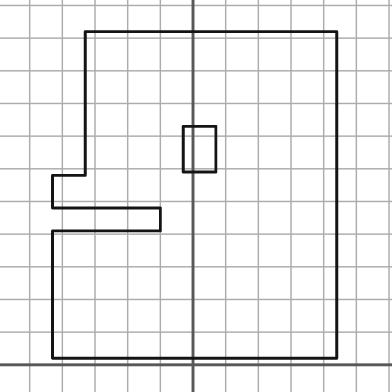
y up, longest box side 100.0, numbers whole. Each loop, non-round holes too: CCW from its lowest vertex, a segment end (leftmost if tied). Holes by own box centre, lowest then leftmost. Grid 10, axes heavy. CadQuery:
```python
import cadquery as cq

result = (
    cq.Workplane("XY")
    .moveTo(-43.0, 2.0)
    .lineTo(44.0, 2.0)
    .lineTo(44.0, 102.0)
    .lineTo(-33.0, 102.0)
    .lineTo(-33.0, 58.0)
    .lineTo(-43.0, 58.0)
    .lineTo(-43.0, 48.0)
    .lineTo(-10.0, 48.0)
    .lineTo(-10.0, 41.0)
    .lineTo(-43.0, 41.0)
    .close()
    .moveTo(-3.0, 59.0)
    .lineTo(7.0, 59.0)
    .lineTo(7.0, 73.0)
    .lineTo(-3.0, 73.0)
    .close()
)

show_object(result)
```